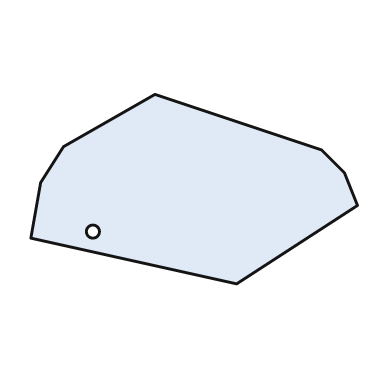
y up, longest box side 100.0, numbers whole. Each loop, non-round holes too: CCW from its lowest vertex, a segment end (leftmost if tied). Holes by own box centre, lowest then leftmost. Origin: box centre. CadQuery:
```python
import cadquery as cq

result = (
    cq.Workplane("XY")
    .moveTo(13.0, -29.0)
    .lineTo(50.0, -5.0)
    .lineTo(46.0, 5.0)
    .lineTo(39.0, 12.0)
    .lineTo(-12.0, 29.0)
    .lineTo(-40.0, 13.0)
    .lineTo(-47.0, 2.0)
    .lineTo(-50.0, -15.0)
    .close()
    .moveTo(-31.0, -13.0)
    .circle(2.0)
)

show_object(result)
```